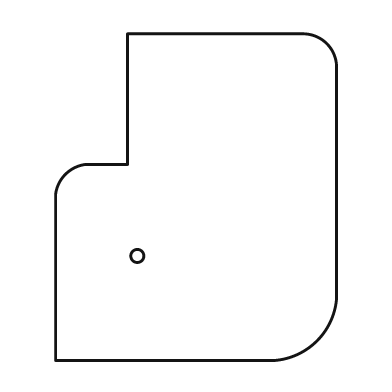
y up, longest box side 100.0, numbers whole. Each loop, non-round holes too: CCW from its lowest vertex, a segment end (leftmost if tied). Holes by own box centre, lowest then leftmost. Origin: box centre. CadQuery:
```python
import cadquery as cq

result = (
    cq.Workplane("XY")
    .moveTo(-43.0, -50.0)
    .lineTo(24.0, -50.0)
    .threePointArc((37.0, -44.0), (43.0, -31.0))
    .lineTo(43.0, 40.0)
    .threePointArc((40.0, 47.0), (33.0, 50.0))
    .lineTo(-21.0, 50.0)
    .lineTo(-21.0, 10.0)
    .lineTo(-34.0, 10.0)
    .threePointArc((-40.0, 7.0), (-43.0, 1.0))
    .close()
    .moveTo(-18.0, -18.0)
    .circle(2.0)
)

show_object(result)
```